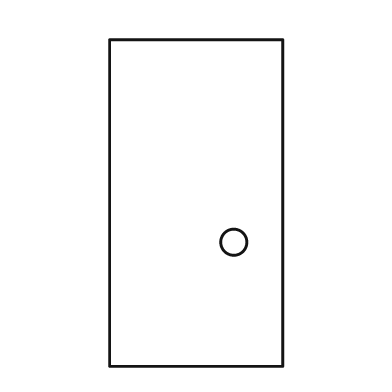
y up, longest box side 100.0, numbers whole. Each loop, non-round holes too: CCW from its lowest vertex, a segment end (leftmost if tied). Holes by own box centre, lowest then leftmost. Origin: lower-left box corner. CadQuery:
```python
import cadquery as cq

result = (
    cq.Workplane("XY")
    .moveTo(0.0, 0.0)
    .lineTo(53.0, 0.0)
    .lineTo(53.0, 100.0)
    .lineTo(0.0, 100.0)
    .close()
    .moveTo(38.0, 38.0)
    .circle(4.0)
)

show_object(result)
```